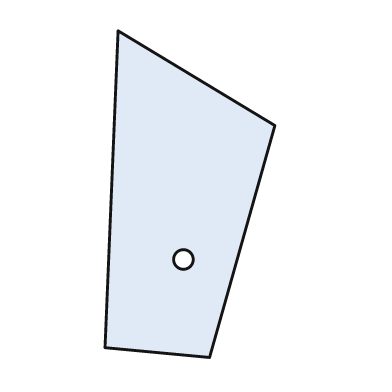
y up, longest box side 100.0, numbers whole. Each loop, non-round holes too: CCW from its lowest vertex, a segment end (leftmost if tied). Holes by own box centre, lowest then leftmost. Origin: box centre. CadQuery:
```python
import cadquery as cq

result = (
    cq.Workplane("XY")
    .moveTo(6.0, -50.0)
    .lineTo(26.0, 21.0)
    .lineTo(-22.0, 50.0)
    .lineTo(-26.0, -47.0)
    .close()
    .moveTo(-2.0, -20.0)
    .circle(3.0)
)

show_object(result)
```